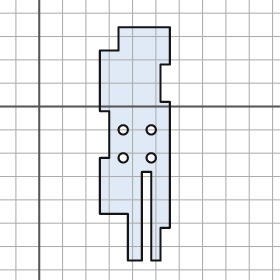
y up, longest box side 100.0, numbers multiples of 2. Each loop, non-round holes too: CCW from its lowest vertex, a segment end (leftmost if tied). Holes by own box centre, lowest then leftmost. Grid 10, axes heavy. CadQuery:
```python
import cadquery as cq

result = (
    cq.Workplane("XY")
    .moveTo(38.0, -66.0)
    .lineTo(44.0, -66.0)
    .lineTo(44.0, -28.0)
    .lineTo(48.0, -28.0)
    .lineTo(48.0, -66.0)
    .lineTo(52.0, -66.0)
    .lineTo(52.0, -52.0)
    .lineTo(56.0, -52.0)
    .lineTo(56.0, 2.0)
    .lineTo(52.0, 2.0)
    .lineTo(52.0, 18.0)
    .lineTo(56.0, 18.0)
    .lineTo(56.0, 34.0)
    .lineTo(34.0, 34.0)
    .lineTo(34.0, 24.0)
    .lineTo(26.0, 24.0)
    .lineTo(26.0, -2.0)
    .lineTo(30.0, -2.0)
    .lineTo(30.0, -22.0)
    .lineTo(26.0, -22.0)
    .lineTo(26.0, -46.0)
    .lineTo(38.0, -46.0)
    .close()
    .moveTo(36.0, -22.0)
    .circle(2.0)
    .moveTo(48.0, -22.0)
    .circle(2.0)
    .moveTo(36.0, -10.0)
    .circle(2.0)
    .moveTo(48.0, -10.0)
    .circle(2.0)
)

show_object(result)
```